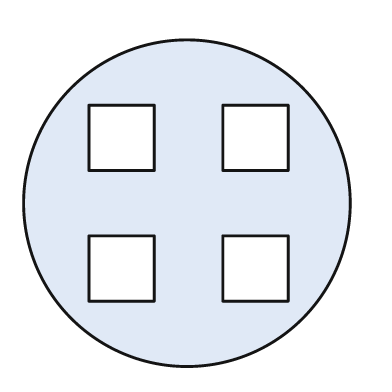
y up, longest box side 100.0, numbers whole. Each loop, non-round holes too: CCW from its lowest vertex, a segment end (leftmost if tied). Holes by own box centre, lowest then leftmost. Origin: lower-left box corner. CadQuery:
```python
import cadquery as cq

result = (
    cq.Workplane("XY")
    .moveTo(50.0, 50.0)
    .circle(50.0)
    .moveTo(20.0, 20.0)
    .lineTo(40.0, 20.0)
    .lineTo(40.0, 40.0)
    .lineTo(20.0, 40.0)
    .close()
    .moveTo(61.0, 20.0)
    .lineTo(81.0, 20.0)
    .lineTo(81.0, 40.0)
    .lineTo(61.0, 40.0)
    .close()
    .moveTo(20.0, 60.0)
    .lineTo(40.0, 60.0)
    .lineTo(40.0, 80.0)
    .lineTo(20.0, 80.0)
    .close()
    .moveTo(61.0, 60.0)
    .lineTo(81.0, 60.0)
    .lineTo(81.0, 80.0)
    .lineTo(61.0, 80.0)
    .close()
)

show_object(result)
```